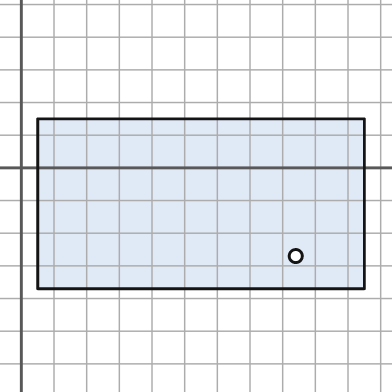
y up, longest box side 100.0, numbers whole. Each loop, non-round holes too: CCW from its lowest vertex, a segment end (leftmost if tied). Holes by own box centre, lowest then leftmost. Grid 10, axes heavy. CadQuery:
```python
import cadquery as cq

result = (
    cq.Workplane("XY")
    .moveTo(5.0, -37.0)
    .lineTo(105.0, -37.0)
    .lineTo(105.0, 15.0)
    .lineTo(5.0, 15.0)
    .close()
    .moveTo(84.0, -27.0)
    .circle(2.0)
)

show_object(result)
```